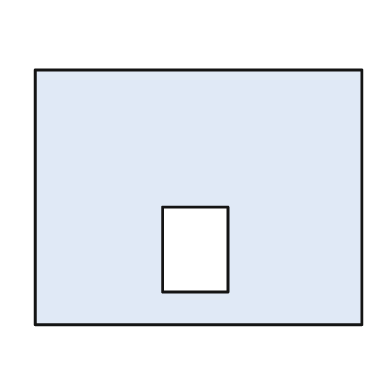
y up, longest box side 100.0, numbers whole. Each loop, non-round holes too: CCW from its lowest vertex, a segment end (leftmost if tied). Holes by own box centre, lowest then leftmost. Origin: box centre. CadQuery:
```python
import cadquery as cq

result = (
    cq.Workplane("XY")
    .moveTo(-50.0, -39.0)
    .lineTo(50.0, -39.0)
    .lineTo(50.0, 39.0)
    .lineTo(-50.0, 39.0)
    .close()
    .moveTo(-11.0, -29.0)
    .lineTo(9.0, -29.0)
    .lineTo(9.0, -3.0)
    .lineTo(-11.0, -3.0)
    .close()
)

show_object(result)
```